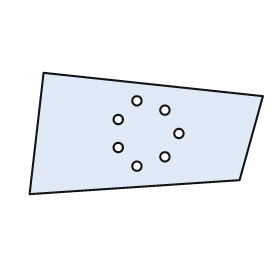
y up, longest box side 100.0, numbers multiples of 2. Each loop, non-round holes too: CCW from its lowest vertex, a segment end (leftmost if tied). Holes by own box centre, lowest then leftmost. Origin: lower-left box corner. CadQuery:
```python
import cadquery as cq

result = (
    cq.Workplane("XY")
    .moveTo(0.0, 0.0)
    .lineTo(90.0, 6.0)
    .lineTo(100.0, 42.0)
    .lineTo(6.0, 52.0)
    .close()
    .moveTo(46.0, 12.0)
    .circle(2.0)
    .moveTo(58.0, 16.0)
    .circle(2.0)
    .moveTo(38.0, 20.0)
    .circle(2.0)
    .moveTo(64.0, 26.0)
    .circle(2.0)
    .moveTo(38.0, 32.0)
    .circle(2.0)
    .moveTo(58.0, 36.0)
    .circle(2.0)
    .moveTo(46.0, 40.0)
    .circle(2.0)
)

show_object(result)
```